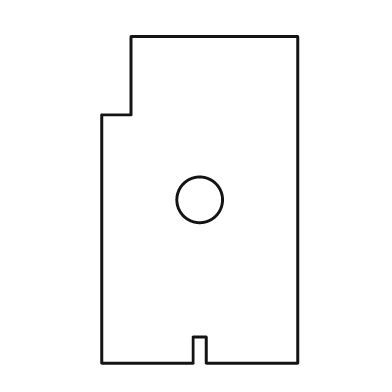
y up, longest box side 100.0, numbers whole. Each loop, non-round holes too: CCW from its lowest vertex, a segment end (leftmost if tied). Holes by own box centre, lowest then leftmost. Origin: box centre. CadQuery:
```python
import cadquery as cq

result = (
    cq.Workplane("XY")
    .moveTo(-30.0, -50.0)
    .lineTo(-2.0, -50.0)
    .lineTo(-2.0, -42.0)
    .lineTo(2.0, -42.0)
    .lineTo(2.0, -50.0)
    .lineTo(30.0, -50.0)
    .lineTo(30.0, 50.0)
    .lineTo(-21.0, 50.0)
    .lineTo(-21.0, 26.0)
    .lineTo(-30.0, 26.0)
    .close()
    .moveTo(0.0, 0.0)
    .circle(7.0)
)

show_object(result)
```